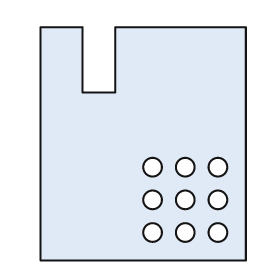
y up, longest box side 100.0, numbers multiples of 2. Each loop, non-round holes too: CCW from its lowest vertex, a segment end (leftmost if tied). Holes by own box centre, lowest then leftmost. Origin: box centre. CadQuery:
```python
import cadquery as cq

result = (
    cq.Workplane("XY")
    .moveTo(-44.0, -50.0)
    .lineTo(44.0, -50.0)
    .lineTo(44.0, 50.0)
    .lineTo(-12.0, 50.0)
    .lineTo(-12.0, 22.0)
    .lineTo(-26.0, 22.0)
    .lineTo(-26.0, 50.0)
    .lineTo(-44.0, 50.0)
    .close()
    .moveTo(4.0, -38.0)
    .circle(4.0)
    .moveTo(18.0, -38.0)
    .circle(4.0)
    .moveTo(32.0, -38.0)
    .circle(4.0)
    .moveTo(4.0, -24.0)
    .circle(4.0)
    .moveTo(18.0, -24.0)
    .circle(4.0)
    .moveTo(32.0, -24.0)
    .circle(4.0)
    .moveTo(4.0, -10.0)
    .circle(4.0)
    .moveTo(18.0, -10.0)
    .circle(4.0)
    .moveTo(32.0, -10.0)
    .circle(4.0)
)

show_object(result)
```